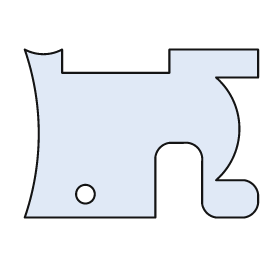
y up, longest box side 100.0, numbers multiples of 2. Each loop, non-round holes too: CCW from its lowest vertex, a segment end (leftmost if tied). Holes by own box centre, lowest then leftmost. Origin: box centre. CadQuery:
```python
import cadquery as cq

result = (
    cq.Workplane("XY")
    .moveTo(-50.0, -36.0)
    .lineTo(6.0, -36.0)
    .lineTo(6.0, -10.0)
    .threePointArc((8.0, -6.0), (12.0, -4.0))
    .lineTo(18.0, -4.0)
    .threePointArc((24.0, -6.0), (26.0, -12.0))
    .lineTo(26.0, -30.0)
    .threePointArc((28.0, -34.0), (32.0, -36.0))
    .lineTo(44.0, -36.0)
    .threePointArc((48.0, -34.0), (50.0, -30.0))
    .lineTo(50.0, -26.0)
    .threePointArc((48.0, -22.0), (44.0, -20.0))
    .lineTo(32.0, -20.0)
    .threePointArc((42.0, 2.0), (32.0, 24.0))
    .lineTo(50.0, 24.0)
    .lineTo(50.0, 36.0)
    .lineTo(12.0, 36.0)
    .lineTo(12.0, 26.0)
    .lineTo(-34.0, 26.0)
    .lineTo(-34.0, 36.0)
    .threePointArc((-42.0, 34.0), (-50.0, 36.0))
    .threePointArc((-44.0, 0.0), (-50.0, -36.0))
    .close()
    .moveTo(-24.0, -26.0)
    .circle(4.0)
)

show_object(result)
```